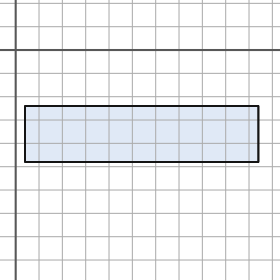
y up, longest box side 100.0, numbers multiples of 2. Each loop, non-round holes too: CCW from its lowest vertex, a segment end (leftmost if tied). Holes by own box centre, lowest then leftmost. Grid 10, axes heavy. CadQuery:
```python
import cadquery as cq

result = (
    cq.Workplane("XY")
    .moveTo(4.0, -48.0)
    .lineTo(104.0, -48.0)
    .lineTo(104.0, -24.0)
    .lineTo(4.0, -24.0)
    .close()
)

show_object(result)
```